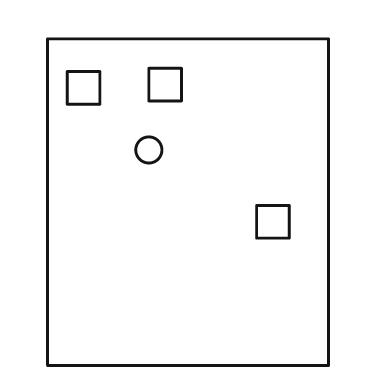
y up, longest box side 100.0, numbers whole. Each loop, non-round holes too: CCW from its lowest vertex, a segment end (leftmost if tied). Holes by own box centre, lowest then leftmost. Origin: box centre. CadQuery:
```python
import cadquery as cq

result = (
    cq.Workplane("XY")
    .moveTo(-43.0, -50.0)
    .lineTo(43.0, -50.0)
    .lineTo(43.0, 50.0)
    .lineTo(-43.0, 50.0)
    .close()
    .moveTo(21.0, -11.0)
    .lineTo(31.0, -11.0)
    .lineTo(31.0, -1.0)
    .lineTo(21.0, -1.0)
    .close()
    .moveTo(-12.0, 16.0)
    .circle(4.0)
    .moveTo(-37.0, 30.0)
    .lineTo(-27.0, 30.0)
    .lineTo(-27.0, 40.0)
    .lineTo(-37.0, 40.0)
    .close()
    .moveTo(-12.0, 31.0)
    .lineTo(-2.0, 31.0)
    .lineTo(-2.0, 41.0)
    .lineTo(-12.0, 41.0)
    .close()
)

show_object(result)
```